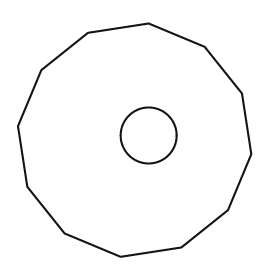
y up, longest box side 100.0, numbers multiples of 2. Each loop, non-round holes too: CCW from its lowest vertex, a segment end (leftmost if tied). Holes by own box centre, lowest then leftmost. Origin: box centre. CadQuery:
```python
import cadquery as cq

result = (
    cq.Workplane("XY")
    .moveTo(-6.0, -50.0)
    .lineTo(20.0, -46.0)
    .lineTo(40.0, -30.0)
    .lineTo(50.0, -6.0)
    .lineTo(46.0, 20.0)
    .lineTo(30.0, 40.0)
    .lineTo(6.0, 50.0)
    .lineTo(-20.0, 46.0)
    .lineTo(-40.0, 30.0)
    .lineTo(-50.0, 6.0)
    .lineTo(-46.0, -20.0)
    .lineTo(-30.0, -40.0)
    .close()
    .moveTo(6.0, 2.0)
    .circle(12.0)
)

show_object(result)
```